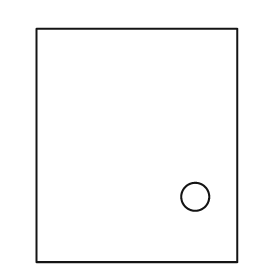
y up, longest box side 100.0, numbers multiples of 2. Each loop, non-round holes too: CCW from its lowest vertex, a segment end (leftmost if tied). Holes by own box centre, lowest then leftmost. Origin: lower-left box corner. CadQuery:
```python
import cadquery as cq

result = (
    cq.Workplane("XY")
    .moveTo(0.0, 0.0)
    .lineTo(86.0, 0.0)
    .lineTo(86.0, 100.0)
    .lineTo(0.0, 100.0)
    .close()
    .moveTo(68.0, 28.0)
    .circle(6.0)
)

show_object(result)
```